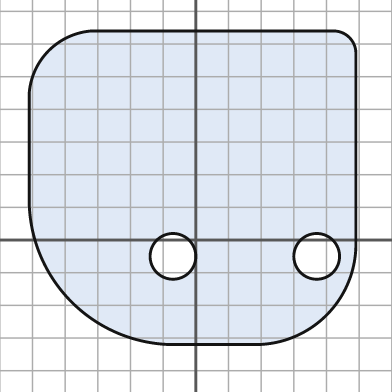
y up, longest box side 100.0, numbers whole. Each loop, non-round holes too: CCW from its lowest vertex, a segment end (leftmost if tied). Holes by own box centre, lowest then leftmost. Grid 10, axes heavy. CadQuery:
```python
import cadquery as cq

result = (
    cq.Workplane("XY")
    .moveTo(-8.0, -32.0)
    .lineTo(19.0, -32.0)
    .threePointArc((40.0, -23.0), (49.0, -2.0))
    .lineTo(49.0, 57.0)
    .threePointArc((47.0, 62.0), (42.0, 64.0))
    .lineTo(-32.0, 64.0)
    .threePointArc((-45.0, 58.0), (-51.0, 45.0))
    .lineTo(-51.0, 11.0)
    .threePointArc((-38.0, -19.0), (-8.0, -32.0))
    .close()
    .moveTo(-7.0, -5.0)
    .circle(7.0)
    .moveTo(37.0, -5.0)
    .circle(7.0)
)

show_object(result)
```